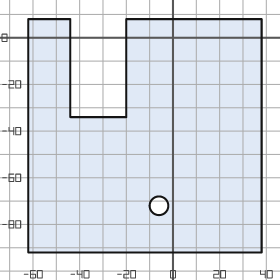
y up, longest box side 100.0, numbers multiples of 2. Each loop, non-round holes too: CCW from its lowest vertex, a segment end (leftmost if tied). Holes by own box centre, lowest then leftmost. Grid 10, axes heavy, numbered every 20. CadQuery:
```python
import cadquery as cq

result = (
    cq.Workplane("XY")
    .moveTo(-62.0, -92.0)
    .lineTo(38.0, -92.0)
    .lineTo(38.0, 8.0)
    .lineTo(-20.0, 8.0)
    .lineTo(-20.0, -34.0)
    .lineTo(-44.0, -34.0)
    .lineTo(-44.0, 8.0)
    .lineTo(-62.0, 8.0)
    .close()
    .moveTo(-6.0, -72.0)
    .circle(4.0)
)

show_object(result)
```